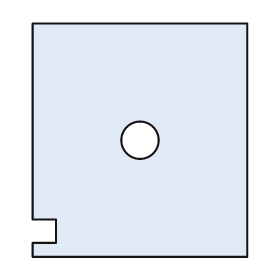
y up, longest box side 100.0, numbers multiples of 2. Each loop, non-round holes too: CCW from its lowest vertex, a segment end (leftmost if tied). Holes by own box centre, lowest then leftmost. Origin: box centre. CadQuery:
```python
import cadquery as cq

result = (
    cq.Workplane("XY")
    .moveTo(-46.0, -50.0)
    .lineTo(46.0, -50.0)
    .lineTo(46.0, 50.0)
    .lineTo(-46.0, 50.0)
    .lineTo(-46.0, -34.0)
    .lineTo(-36.0, -34.0)
    .lineTo(-36.0, -44.0)
    .lineTo(-46.0, -44.0)
    .close()
    .moveTo(0.0, 0.0)
    .circle(8.0)
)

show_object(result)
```